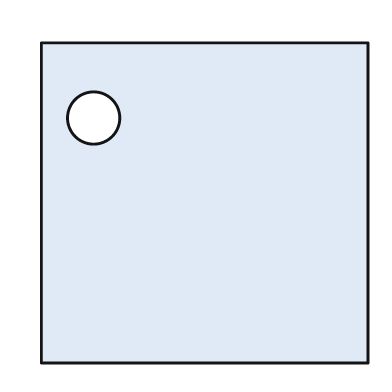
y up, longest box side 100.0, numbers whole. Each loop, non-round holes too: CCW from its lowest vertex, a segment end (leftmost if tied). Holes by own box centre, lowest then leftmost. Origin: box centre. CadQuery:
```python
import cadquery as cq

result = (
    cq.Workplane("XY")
    .moveTo(-50.0, -49.0)
    .lineTo(50.0, -49.0)
    .lineTo(50.0, 49.0)
    .lineTo(-50.0, 49.0)
    .close()
    .moveTo(-34.0, 26.0)
    .circle(8.0)
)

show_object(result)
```